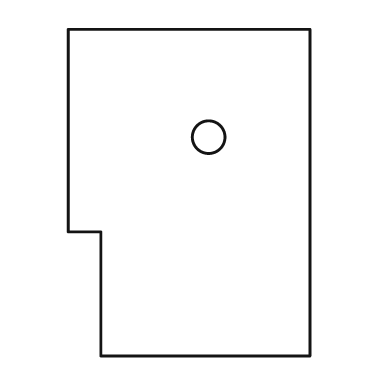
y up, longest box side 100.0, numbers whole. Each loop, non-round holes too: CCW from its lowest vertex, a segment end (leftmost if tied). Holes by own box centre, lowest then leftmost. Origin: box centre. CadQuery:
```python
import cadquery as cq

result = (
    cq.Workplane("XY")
    .moveTo(-27.0, -50.0)
    .lineTo(37.0, -50.0)
    .lineTo(37.0, 50.0)
    .lineTo(-37.0, 50.0)
    .lineTo(-37.0, -12.0)
    .lineTo(-27.0, -12.0)
    .close()
    .moveTo(6.0, 17.0)
    .circle(5.0)
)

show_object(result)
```